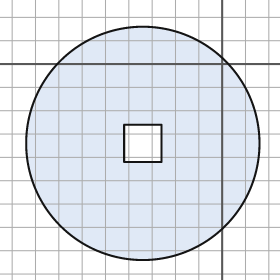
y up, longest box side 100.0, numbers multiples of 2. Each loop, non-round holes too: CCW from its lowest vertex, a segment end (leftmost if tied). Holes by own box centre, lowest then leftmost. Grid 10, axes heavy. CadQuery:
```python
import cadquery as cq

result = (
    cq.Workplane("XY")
    .moveTo(-34.0, -34.0)
    .circle(50.0)
    .moveTo(-42.0, -42.0)
    .lineTo(-26.0, -42.0)
    .lineTo(-26.0, -26.0)
    .lineTo(-42.0, -26.0)
    .close()
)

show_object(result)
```